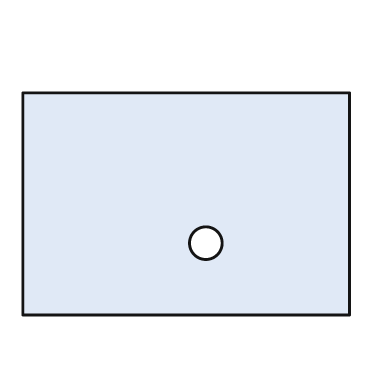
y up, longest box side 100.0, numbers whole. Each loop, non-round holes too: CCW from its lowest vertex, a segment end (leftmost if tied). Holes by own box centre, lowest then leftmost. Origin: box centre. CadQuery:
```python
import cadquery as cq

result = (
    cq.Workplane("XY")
    .moveTo(-50.0, -34.0)
    .lineTo(50.0, -34.0)
    .lineTo(50.0, 34.0)
    .lineTo(-50.0, 34.0)
    .close()
    .moveTo(6.0, -12.0)
    .circle(5.0)
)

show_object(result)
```